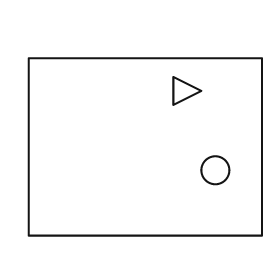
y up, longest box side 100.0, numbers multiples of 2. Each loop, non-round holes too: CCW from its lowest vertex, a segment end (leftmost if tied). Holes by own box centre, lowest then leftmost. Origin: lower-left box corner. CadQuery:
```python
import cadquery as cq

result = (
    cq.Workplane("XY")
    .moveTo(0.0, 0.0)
    .lineTo(100.0, 0.0)
    .lineTo(100.0, 76.0)
    .lineTo(0.0, 76.0)
    .close()
    .moveTo(80.0, 28.0)
    .circle(6.0)
    .moveTo(62.0, 56.0)
    .lineTo(74.0, 62.0)
    .lineTo(62.0, 68.0)
    .close()
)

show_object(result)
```